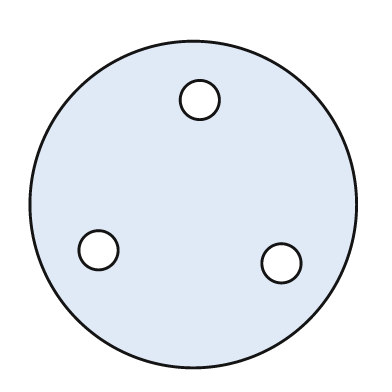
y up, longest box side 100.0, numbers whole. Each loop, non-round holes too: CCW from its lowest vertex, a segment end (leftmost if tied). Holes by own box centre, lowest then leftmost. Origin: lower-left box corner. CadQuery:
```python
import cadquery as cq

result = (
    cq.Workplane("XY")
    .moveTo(50.0, 50.0)
    .circle(50.0)
    .moveTo(77.0, 32.0)
    .circle(6.0)
    .moveTo(21.0, 36.0)
    .circle(6.0)
    .moveTo(52.0, 82.0)
    .circle(6.0)
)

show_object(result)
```